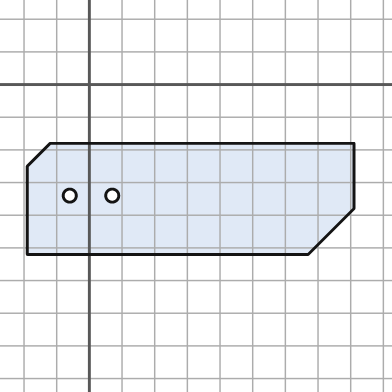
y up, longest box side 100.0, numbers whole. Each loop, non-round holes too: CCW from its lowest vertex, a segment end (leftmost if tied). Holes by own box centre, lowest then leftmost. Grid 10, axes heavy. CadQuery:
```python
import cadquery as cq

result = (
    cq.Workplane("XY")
    .moveTo(-19.0, -52.0)
    .lineTo(67.0, -52.0)
    .lineTo(81.0, -38.0)
    .lineTo(81.0, -18.0)
    .lineTo(-12.0, -18.0)
    .lineTo(-19.0, -25.0)
    .close()
    .moveTo(-6.0, -34.0)
    .circle(2.0)
    .moveTo(7.0, -34.0)
    .circle(2.0)
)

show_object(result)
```